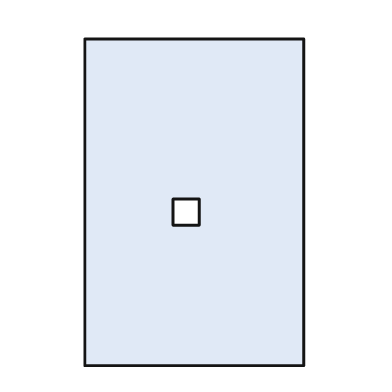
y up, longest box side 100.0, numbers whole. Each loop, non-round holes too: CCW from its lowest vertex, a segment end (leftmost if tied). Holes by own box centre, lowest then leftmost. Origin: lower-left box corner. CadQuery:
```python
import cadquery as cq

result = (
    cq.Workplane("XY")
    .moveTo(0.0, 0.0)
    .lineTo(67.0, 0.0)
    .lineTo(67.0, 100.0)
    .lineTo(0.0, 100.0)
    .close()
    .moveTo(27.0, 43.0)
    .lineTo(35.0, 43.0)
    .lineTo(35.0, 51.0)
    .lineTo(27.0, 51.0)
    .close()
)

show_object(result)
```